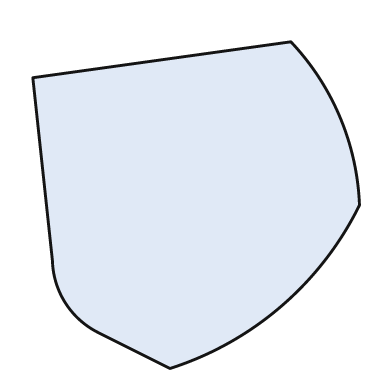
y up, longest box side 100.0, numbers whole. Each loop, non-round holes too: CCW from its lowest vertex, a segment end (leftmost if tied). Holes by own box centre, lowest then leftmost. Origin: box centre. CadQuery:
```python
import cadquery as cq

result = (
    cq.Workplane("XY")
    .moveTo(-8.0, -50.0)
    .threePointArc((26.0, -31.0), (50.0, 0.0))
    .threePointArc((44.0, 27.0), (29.0, 50.0))
    .lineTo(-50.0, 39.0)
    .lineTo(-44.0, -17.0)
    .threePointArc((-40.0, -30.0), (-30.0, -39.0))
    .close()
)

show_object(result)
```